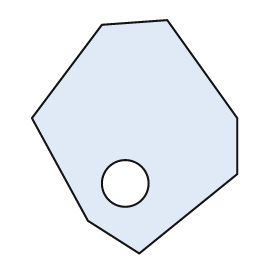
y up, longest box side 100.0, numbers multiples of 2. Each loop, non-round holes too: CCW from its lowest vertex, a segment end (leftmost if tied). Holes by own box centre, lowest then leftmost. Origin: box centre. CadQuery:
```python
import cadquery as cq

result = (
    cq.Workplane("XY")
    .moveTo(2.0, -50.0)
    .lineTo(44.0, -16.0)
    .lineTo(44.0, 8.0)
    .lineTo(14.0, 50.0)
    .lineTo(-14.0, 48.0)
    .lineTo(-44.0, 8.0)
    .lineTo(-20.0, -36.0)
    .close()
    .moveTo(-4.0, -20.0)
    .circle(10.0)
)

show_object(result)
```